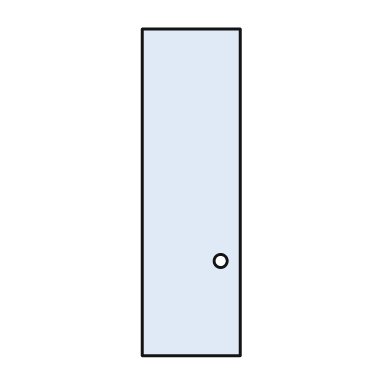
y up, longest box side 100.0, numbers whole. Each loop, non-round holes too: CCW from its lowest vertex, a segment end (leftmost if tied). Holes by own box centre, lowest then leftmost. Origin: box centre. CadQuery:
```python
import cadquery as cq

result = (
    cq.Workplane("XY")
    .moveTo(-15.0, -50.0)
    .lineTo(15.0, -50.0)
    .lineTo(15.0, 50.0)
    .lineTo(-15.0, 50.0)
    .close()
    .moveTo(9.0, -21.0)
    .circle(2.0)
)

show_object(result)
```